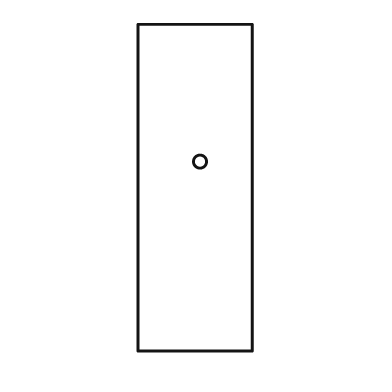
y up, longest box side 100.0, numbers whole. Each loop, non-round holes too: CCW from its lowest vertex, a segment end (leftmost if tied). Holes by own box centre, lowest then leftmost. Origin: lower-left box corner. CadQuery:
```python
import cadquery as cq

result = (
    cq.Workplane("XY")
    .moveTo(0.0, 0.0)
    .lineTo(35.0, 0.0)
    .lineTo(35.0, 100.0)
    .lineTo(0.0, 100.0)
    .close()
    .moveTo(19.0, 58.0)
    .circle(2.0)
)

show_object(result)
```